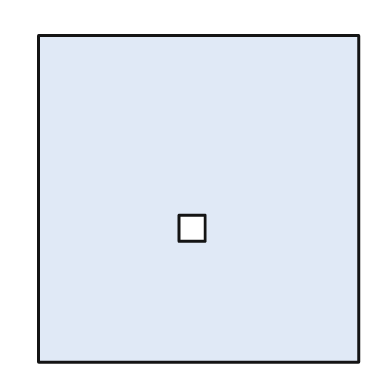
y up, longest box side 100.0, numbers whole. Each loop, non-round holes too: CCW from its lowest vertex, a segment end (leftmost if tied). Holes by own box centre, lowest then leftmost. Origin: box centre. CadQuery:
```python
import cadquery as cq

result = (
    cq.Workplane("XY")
    .moveTo(-49.0, -50.0)
    .lineTo(49.0, -50.0)
    .lineTo(49.0, 50.0)
    .lineTo(-49.0, 50.0)
    .close()
    .moveTo(-6.0, -13.0)
    .lineTo(2.0, -13.0)
    .lineTo(2.0, -5.0)
    .lineTo(-6.0, -5.0)
    .close()
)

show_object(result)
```